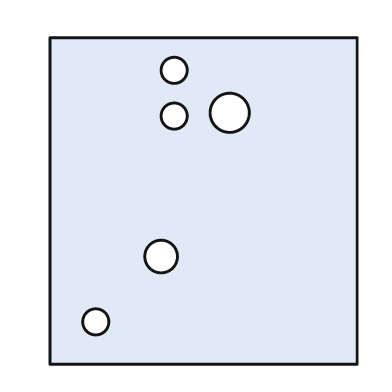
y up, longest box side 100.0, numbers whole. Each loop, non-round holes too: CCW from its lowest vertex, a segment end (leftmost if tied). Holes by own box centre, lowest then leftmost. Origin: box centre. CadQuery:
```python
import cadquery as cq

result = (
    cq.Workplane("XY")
    .moveTo(-47.0, -50.0)
    .lineTo(47.0, -50.0)
    .lineTo(47.0, 50.0)
    .lineTo(-47.0, 50.0)
    .close()
    .moveTo(-33.0, -37.0)
    .circle(4.0)
    .moveTo(-13.0, -17.0)
    .circle(5.0)
    .moveTo(-9.0, 26.0)
    .circle(4.0)
    .moveTo(8.0, 27.0)
    .circle(6.0)
    .moveTo(-9.0, 40.0)
    .circle(4.0)
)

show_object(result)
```